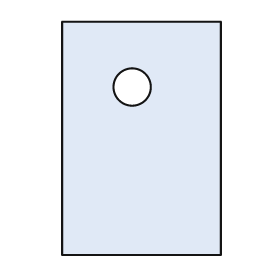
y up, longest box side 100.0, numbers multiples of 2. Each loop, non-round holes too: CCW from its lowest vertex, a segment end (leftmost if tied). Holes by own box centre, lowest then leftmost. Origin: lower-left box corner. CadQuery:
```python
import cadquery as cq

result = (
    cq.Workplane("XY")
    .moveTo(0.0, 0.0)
    .lineTo(68.0, 0.0)
    .lineTo(68.0, 100.0)
    .lineTo(0.0, 100.0)
    .close()
    .moveTo(30.0, 72.0)
    .circle(8.0)
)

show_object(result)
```